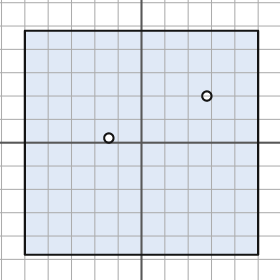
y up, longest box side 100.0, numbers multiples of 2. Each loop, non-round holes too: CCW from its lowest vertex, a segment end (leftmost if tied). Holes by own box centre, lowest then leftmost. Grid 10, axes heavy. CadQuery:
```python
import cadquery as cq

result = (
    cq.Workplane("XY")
    .moveTo(-50.0, -48.0)
    .lineTo(50.0, -48.0)
    .lineTo(50.0, 48.0)
    .lineTo(-50.0, 48.0)
    .close()
    .moveTo(-14.0, 2.0)
    .circle(2.0)
    .moveTo(28.0, 20.0)
    .circle(2.0)
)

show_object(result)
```